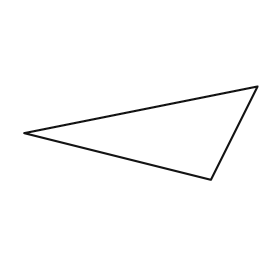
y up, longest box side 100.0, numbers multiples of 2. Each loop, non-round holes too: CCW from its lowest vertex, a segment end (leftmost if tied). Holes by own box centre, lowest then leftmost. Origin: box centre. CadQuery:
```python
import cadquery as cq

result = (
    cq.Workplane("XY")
    .moveTo(30.0, -20.0)
    .lineTo(50.0, 20.0)
    .lineTo(-50.0, 0.0)
    .close()
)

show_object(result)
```